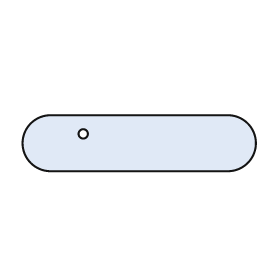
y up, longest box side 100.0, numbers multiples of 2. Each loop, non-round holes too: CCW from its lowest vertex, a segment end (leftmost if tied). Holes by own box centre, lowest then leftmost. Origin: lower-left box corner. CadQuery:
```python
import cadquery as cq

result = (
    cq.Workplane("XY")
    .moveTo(12.0, 0.0)
    .lineTo(88.0, 0.0)
    .threePointArc((100.0, 12.0), (88.0, 24.0))
    .lineTo(12.0, 24.0)
    .threePointArc((0.0, 12.0), (12.0, 0.0))
    .close()
    .moveTo(26.0, 16.0)
    .circle(2.0)
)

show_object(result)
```